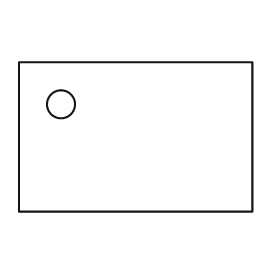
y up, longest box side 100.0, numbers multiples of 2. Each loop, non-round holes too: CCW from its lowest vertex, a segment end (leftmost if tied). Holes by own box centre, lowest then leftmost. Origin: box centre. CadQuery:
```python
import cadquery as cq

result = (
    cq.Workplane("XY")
    .moveTo(-50.0, -32.0)
    .lineTo(50.0, -32.0)
    .lineTo(50.0, 32.0)
    .lineTo(-50.0, 32.0)
    .close()
    .moveTo(-32.0, 14.0)
    .circle(6.0)
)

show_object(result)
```